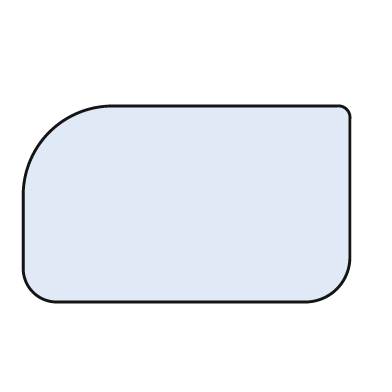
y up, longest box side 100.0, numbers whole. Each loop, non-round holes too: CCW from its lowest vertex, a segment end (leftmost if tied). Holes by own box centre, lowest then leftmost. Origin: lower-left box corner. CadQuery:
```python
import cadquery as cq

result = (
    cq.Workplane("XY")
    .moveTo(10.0, 0.0)
    .lineTo(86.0, 0.0)
    .threePointArc((96.0, 4.0), (100.0, 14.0))
    .lineTo(100.0, 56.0)
    .threePointArc((99.0, 59.0), (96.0, 60.0))
    .lineTo(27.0, 60.0)
    .threePointArc((8.0, 52.0), (0.0, 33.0))
    .lineTo(0.0, 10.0)
    .threePointArc((3.0, 3.0), (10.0, 0.0))
    .close()
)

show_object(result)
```